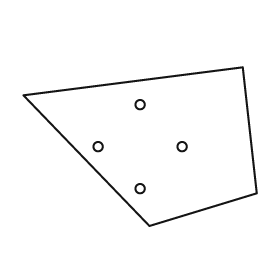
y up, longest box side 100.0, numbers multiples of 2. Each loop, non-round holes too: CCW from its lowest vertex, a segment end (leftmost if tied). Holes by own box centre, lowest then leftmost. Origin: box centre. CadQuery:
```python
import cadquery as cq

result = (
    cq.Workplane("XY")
    .moveTo(4.0, -34.0)
    .lineTo(50.0, -20.0)
    .lineTo(44.0, 34.0)
    .lineTo(-50.0, 22.0)
    .close()
    .moveTo(0.0, -18.0)
    .circle(2.0)
    .moveTo(-18.0, 0.0)
    .circle(2.0)
    .moveTo(18.0, 0.0)
    .circle(2.0)
    .moveTo(0.0, 18.0)
    .circle(2.0)
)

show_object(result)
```